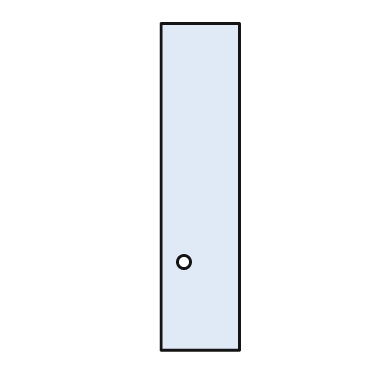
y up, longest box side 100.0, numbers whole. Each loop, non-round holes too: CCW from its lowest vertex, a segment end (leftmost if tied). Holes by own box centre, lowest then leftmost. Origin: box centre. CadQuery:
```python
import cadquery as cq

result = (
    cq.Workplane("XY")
    .moveTo(-12.0, -50.0)
    .lineTo(12.0, -50.0)
    .lineTo(12.0, 50.0)
    .lineTo(-12.0, 50.0)
    .close()
    .moveTo(-5.0, -23.0)
    .circle(2.0)
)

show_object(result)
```